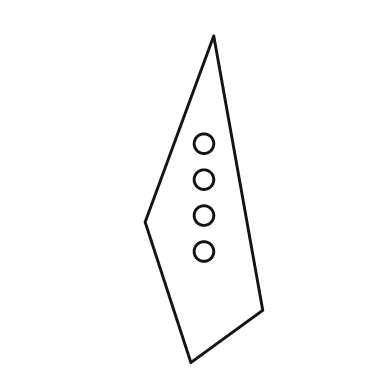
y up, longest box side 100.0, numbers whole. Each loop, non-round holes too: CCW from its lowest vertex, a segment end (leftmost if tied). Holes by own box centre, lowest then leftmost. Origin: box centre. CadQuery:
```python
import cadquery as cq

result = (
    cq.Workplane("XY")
    .moveTo(-4.0, -50.0)
    .lineTo(18.0, -34.0)
    .lineTo(3.0, 50.0)
    .lineTo(-18.0, -7.0)
    .close()
    .moveTo(0.0, -16.0)
    .circle(3.0)
    .moveTo(0.0, -5.0)
    .circle(3.0)
    .moveTo(0.0, 6.0)
    .circle(3.0)
    .moveTo(0.0, 17.0)
    .circle(3.0)
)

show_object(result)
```